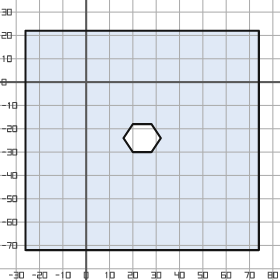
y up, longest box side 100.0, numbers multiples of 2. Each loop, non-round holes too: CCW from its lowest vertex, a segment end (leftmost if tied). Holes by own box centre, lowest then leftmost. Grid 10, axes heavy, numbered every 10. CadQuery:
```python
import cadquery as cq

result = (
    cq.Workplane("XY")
    .moveTo(-26.0, -72.0)
    .lineTo(74.0, -72.0)
    .lineTo(74.0, 22.0)
    .lineTo(-26.0, 22.0)
    .close()
    .moveTo(20.0, -30.0)
    .lineTo(28.0, -30.0)
    .lineTo(32.0, -24.0)
    .lineTo(28.0, -18.0)
    .lineTo(20.0, -18.0)
    .lineTo(16.0, -24.0)
    .close()
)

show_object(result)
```